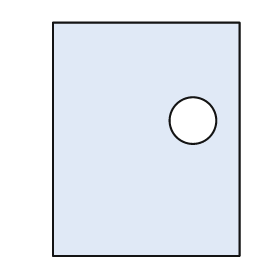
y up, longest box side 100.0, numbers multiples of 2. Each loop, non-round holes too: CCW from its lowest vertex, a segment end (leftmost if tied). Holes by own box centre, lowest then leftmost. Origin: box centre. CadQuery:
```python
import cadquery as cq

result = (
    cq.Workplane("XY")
    .moveTo(-40.0, -50.0)
    .lineTo(40.0, -50.0)
    .lineTo(40.0, 50.0)
    .lineTo(-40.0, 50.0)
    .close()
    .moveTo(20.0, 8.0)
    .circle(10.0)
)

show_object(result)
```